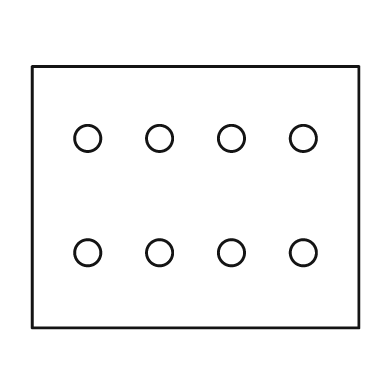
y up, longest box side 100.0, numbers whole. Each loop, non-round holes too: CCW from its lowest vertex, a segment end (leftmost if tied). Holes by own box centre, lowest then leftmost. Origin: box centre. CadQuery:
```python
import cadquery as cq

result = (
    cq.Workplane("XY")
    .moveTo(-50.0, -40.0)
    .lineTo(50.0, -40.0)
    .lineTo(50.0, 40.0)
    .lineTo(-50.0, 40.0)
    .close()
    .moveTo(-33.0, -17.0)
    .circle(4.0)
    .moveTo(-11.0, -17.0)
    .circle(4.0)
    .moveTo(11.0, -17.0)
    .circle(4.0)
    .moveTo(33.0, -17.0)
    .circle(4.0)
    .moveTo(-33.0, 18.0)
    .circle(4.0)
    .moveTo(-11.0, 18.0)
    .circle(4.0)
    .moveTo(11.0, 18.0)
    .circle(4.0)
    .moveTo(33.0, 18.0)
    .circle(4.0)
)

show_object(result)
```